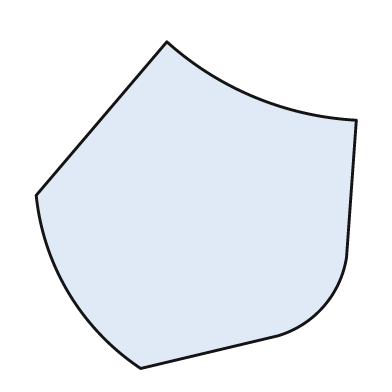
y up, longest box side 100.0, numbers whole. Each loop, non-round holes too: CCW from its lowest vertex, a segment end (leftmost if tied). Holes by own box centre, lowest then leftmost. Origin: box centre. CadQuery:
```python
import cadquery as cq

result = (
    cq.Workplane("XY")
    .moveTo(-17.0, -50.0)
    .lineTo(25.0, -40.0)
    .threePointArc((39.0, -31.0), (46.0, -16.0))
    .lineTo(49.0, 26.0)
    .threePointArc((18.0, 33.0), (-9.0, 50.0))
    .lineTo(-49.0, 3.0)
    .threePointArc((-39.0, -27.0), (-17.0, -50.0))
    .close()
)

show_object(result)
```